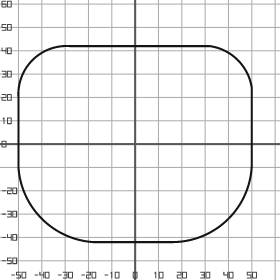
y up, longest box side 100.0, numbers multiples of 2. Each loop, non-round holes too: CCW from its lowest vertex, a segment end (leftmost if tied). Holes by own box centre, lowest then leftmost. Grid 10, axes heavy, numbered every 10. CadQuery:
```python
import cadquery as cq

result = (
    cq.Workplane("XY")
    .moveTo(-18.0, -42.0)
    .lineTo(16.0, -42.0)
    .threePointArc((40.0, -32.0), (50.0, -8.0))
    .lineTo(50.0, 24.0)
    .threePointArc((44.0, 36.0), (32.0, 42.0))
    .lineTo(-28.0, 42.0)
    .threePointArc((-44.0, 36.0), (-50.0, 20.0))
    .lineTo(-50.0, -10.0)
    .threePointArc((-40.0, -32.0), (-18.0, -42.0))
    .close()
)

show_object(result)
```